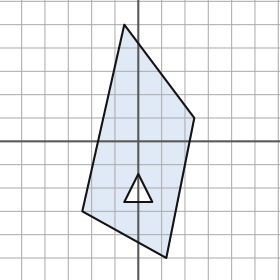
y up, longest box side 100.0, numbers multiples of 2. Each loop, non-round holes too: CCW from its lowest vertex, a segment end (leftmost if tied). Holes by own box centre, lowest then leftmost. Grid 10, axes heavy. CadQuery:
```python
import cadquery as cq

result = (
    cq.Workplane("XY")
    .moveTo(12.0, -50.0)
    .lineTo(24.0, 10.0)
    .lineTo(-6.0, 50.0)
    .lineTo(-24.0, -30.0)
    .close()
    .moveTo(-6.0, -26.0)
    .lineTo(6.0, -26.0)
    .lineTo(0.0, -14.0)
    .close()
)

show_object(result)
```